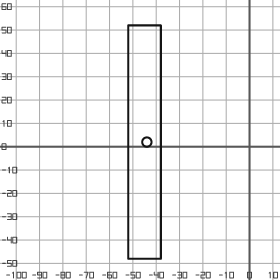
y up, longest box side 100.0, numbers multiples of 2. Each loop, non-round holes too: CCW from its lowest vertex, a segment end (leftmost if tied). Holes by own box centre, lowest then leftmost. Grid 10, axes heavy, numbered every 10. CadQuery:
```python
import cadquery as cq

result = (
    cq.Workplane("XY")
    .moveTo(-52.0, -48.0)
    .lineTo(-38.0, -48.0)
    .lineTo(-38.0, 52.0)
    .lineTo(-52.0, 52.0)
    .close()
    .moveTo(-44.0, 2.0)
    .circle(2.0)
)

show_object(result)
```